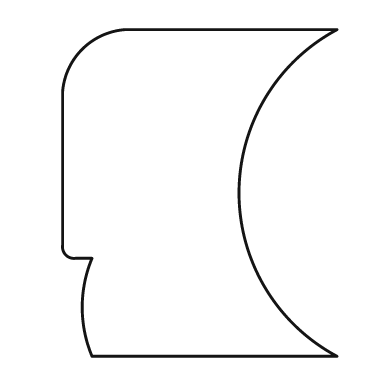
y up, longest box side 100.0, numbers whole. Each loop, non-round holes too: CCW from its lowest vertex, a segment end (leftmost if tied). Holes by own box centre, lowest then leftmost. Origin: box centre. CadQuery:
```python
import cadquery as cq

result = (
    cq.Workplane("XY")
    .moveTo(-33.0, -50.0)
    .lineTo(42.0, -50.0)
    .threePointArc((12.0, 0.0), (42.0, 50.0))
    .lineTo(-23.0, 50.0)
    .threePointArc((-36.0, 44.0), (-42.0, 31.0))
    .lineTo(-42.0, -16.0)
    .threePointArc((-41.0, -19.0), (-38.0, -20.0))
    .lineTo(-33.0, -20.0)
    .threePointArc((-36.0, -35.0), (-33.0, -50.0))
    .close()
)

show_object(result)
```